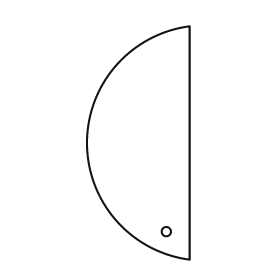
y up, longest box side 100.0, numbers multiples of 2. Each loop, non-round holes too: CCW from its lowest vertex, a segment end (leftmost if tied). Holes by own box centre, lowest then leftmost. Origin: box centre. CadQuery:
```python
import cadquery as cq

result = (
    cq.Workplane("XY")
    .moveTo(22.0, -50.0)
    .lineTo(22.0, 50.0)
    .threePointArc((-22.0, 0.0), (22.0, -50.0))
    .close()
    .moveTo(12.0, -38.0)
    .circle(2.0)
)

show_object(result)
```